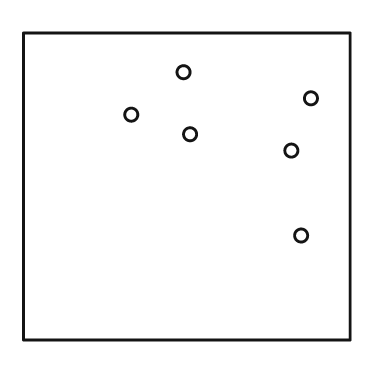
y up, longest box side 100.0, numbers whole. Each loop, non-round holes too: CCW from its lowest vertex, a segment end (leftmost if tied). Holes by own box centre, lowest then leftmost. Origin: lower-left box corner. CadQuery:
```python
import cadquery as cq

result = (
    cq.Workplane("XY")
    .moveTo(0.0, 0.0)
    .lineTo(100.0, 0.0)
    .lineTo(100.0, 94.0)
    .lineTo(0.0, 94.0)
    .close()
    .moveTo(85.0, 32.0)
    .circle(2.0)
    .moveTo(82.0, 58.0)
    .circle(2.0)
    .moveTo(51.0, 63.0)
    .circle(2.0)
    .moveTo(33.0, 69.0)
    .circle(2.0)
    .moveTo(88.0, 74.0)
    .circle(2.0)
    .moveTo(49.0, 82.0)
    .circle(2.0)
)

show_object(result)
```